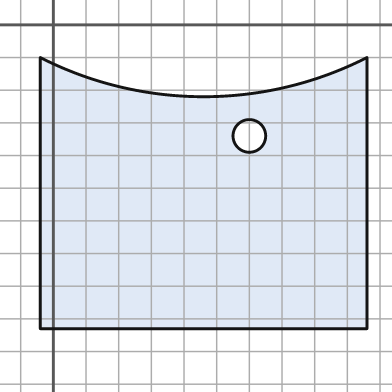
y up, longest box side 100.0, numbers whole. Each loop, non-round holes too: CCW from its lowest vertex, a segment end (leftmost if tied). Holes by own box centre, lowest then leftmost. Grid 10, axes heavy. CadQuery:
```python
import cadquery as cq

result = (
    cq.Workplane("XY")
    .moveTo(-4.0, -93.0)
    .lineTo(96.0, -93.0)
    .lineTo(96.0, -10.0)
    .threePointArc((46.0, -22.0), (-4.0, -10.0))
    .close()
    .moveTo(60.0, -34.0)
    .circle(5.0)
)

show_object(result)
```